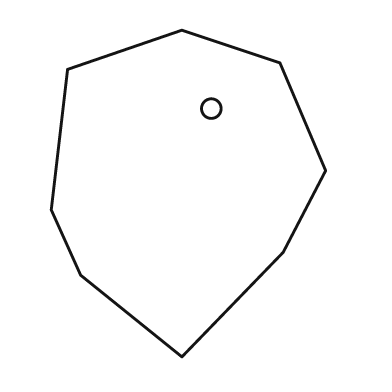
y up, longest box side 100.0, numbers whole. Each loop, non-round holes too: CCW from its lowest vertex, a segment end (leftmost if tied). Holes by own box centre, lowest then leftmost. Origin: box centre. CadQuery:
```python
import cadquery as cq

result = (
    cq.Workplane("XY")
    .moveTo(-2.0, -50.0)
    .lineTo(29.0, -18.0)
    .lineTo(42.0, 7.0)
    .lineTo(28.0, 40.0)
    .lineTo(-2.0, 50.0)
    .lineTo(-37.0, 38.0)
    .lineTo(-42.0, -5.0)
    .lineTo(-33.0, -25.0)
    .close()
    .moveTo(7.0, 26.0)
    .circle(3.0)
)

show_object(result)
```